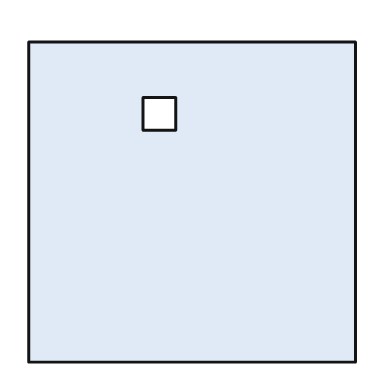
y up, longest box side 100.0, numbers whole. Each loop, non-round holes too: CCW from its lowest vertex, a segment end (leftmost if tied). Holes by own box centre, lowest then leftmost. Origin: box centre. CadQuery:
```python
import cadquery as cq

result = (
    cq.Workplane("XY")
    .moveTo(-50.0, -49.0)
    .lineTo(50.0, -49.0)
    .lineTo(50.0, 49.0)
    .lineTo(-50.0, 49.0)
    .close()
    .moveTo(-15.0, 22.0)
    .lineTo(-5.0, 22.0)
    .lineTo(-5.0, 32.0)
    .lineTo(-15.0, 32.0)
    .close()
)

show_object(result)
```